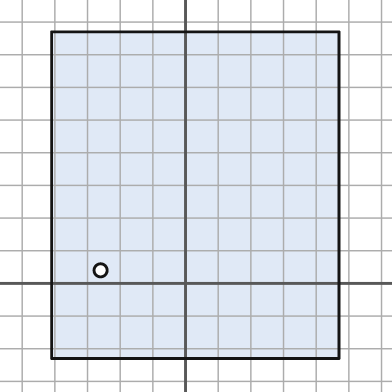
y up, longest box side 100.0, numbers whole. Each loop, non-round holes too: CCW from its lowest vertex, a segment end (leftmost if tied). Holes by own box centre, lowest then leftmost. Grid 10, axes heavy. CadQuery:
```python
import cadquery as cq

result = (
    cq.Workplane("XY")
    .moveTo(-41.0, -23.0)
    .lineTo(47.0, -23.0)
    .lineTo(47.0, 77.0)
    .lineTo(-41.0, 77.0)
    .close()
    .moveTo(-26.0, 4.0)
    .circle(2.0)
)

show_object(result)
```